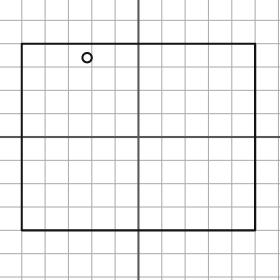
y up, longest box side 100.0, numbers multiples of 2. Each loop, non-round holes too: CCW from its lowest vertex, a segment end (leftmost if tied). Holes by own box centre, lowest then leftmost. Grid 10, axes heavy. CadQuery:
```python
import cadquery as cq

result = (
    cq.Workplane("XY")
    .moveTo(-50.0, -40.0)
    .lineTo(50.0, -40.0)
    .lineTo(50.0, 40.0)
    .lineTo(-50.0, 40.0)
    .close()
    .moveTo(-22.0, 34.0)
    .circle(2.0)
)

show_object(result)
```